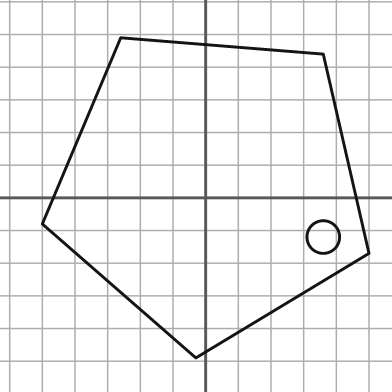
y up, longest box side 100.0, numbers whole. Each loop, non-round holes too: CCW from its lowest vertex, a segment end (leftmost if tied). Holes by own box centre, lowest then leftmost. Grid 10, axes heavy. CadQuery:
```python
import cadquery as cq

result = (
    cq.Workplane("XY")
    .moveTo(-3.0, -49.0)
    .lineTo(50.0, -17.0)
    .lineTo(36.0, 44.0)
    .lineTo(-26.0, 49.0)
    .lineTo(-50.0, -8.0)
    .close()
    .moveTo(36.0, -12.0)
    .circle(5.0)
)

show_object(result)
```